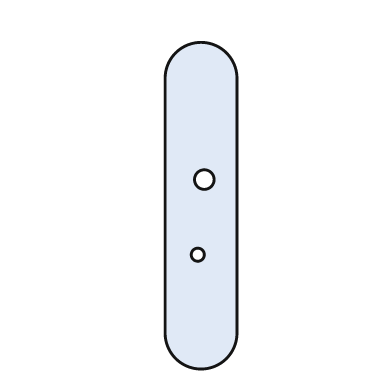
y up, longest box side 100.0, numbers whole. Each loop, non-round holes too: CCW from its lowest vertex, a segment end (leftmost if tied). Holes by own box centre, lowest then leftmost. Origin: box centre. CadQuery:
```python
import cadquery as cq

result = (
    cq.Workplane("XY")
    .moveTo(-11.0, -39.0)
    .threePointArc((0.0, -50.0), (11.0, -39.0))
    .lineTo(11.0, 39.0)
    .threePointArc((0.0, 50.0), (-11.0, 39.0))
    .close()
    .moveTo(-1.0, -15.0)
    .circle(2.0)
    .moveTo(1.0, 8.0)
    .circle(3.0)
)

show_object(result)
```